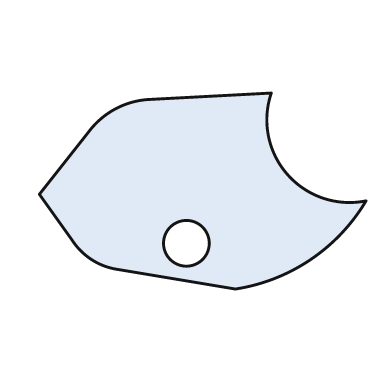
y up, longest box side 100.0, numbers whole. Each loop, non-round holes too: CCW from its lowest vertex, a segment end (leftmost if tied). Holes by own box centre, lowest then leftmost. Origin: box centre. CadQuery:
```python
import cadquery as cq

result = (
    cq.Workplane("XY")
    .moveTo(10.0, -30.0)
    .threePointArc((33.0, -21.0), (50.0, -3.0))
    .threePointArc((26.0, 5.0), (21.0, 30.0))
    .lineTo(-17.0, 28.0)
    .threePointArc((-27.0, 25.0), (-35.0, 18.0))
    .lineTo(-50.0, -1.0)
    .lineTo(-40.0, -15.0)
    .threePointArc((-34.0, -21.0), (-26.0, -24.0))
    .close()
    .moveTo(-5.0, -16.0)
    .circle(7.0)
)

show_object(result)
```